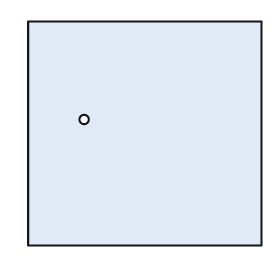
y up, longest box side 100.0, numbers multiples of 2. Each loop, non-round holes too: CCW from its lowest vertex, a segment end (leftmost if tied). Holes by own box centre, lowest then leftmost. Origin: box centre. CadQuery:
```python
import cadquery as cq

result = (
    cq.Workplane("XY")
    .moveTo(-50.0, -48.0)
    .lineTo(50.0, -48.0)
    .lineTo(50.0, 48.0)
    .lineTo(-50.0, 48.0)
    .close()
    .moveTo(-26.0, 6.0)
    .circle(2.0)
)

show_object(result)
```